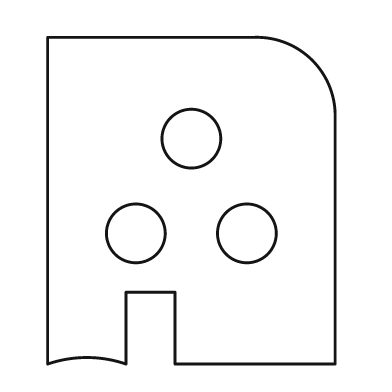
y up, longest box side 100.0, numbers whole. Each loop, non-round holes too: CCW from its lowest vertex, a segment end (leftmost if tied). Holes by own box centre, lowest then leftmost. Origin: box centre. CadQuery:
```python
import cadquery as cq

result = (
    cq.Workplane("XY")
    .moveTo(-44.0, -50.0)
    .threePointArc((-32.0, -48.0), (-20.0, -50.0))
    .lineTo(-20.0, -28.0)
    .lineTo(-5.0, -28.0)
    .lineTo(-5.0, -50.0)
    .lineTo(44.0, -50.0)
    .lineTo(44.0, 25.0)
    .threePointArc((37.0, 43.0), (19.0, 50.0))
    .lineTo(-44.0, 50.0)
    .close()
    .moveTo(-17.0, -10.0)
    .circle(9.0)
    .moveTo(17.0, -10.0)
    .circle(9.0)
    .moveTo(0.0, 19.0)
    .circle(9.0)
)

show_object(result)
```